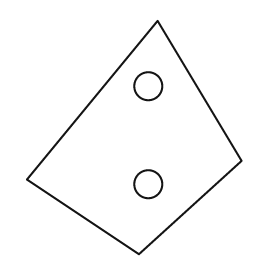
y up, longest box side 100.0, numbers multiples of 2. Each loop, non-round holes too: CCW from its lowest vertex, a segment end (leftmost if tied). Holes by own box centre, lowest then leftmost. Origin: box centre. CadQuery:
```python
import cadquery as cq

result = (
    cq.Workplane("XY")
    .moveTo(2.0, -50.0)
    .lineTo(46.0, -10.0)
    .lineTo(10.0, 50.0)
    .lineTo(-46.0, -18.0)
    .close()
    .moveTo(6.0, -20.0)
    .circle(6.0)
    .moveTo(6.0, 22.0)
    .circle(6.0)
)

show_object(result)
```